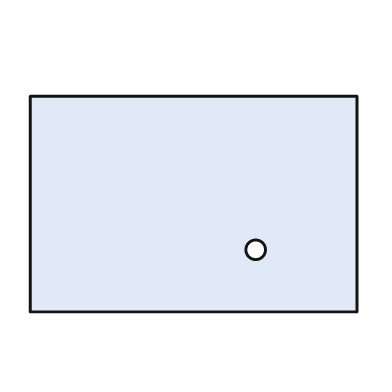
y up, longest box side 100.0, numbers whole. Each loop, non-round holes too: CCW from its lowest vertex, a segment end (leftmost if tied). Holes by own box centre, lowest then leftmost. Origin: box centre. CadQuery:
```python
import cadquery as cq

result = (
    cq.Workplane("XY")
    .moveTo(-50.0, -33.0)
    .lineTo(50.0, -33.0)
    .lineTo(50.0, 33.0)
    .lineTo(-50.0, 33.0)
    .close()
    .moveTo(19.0, -14.0)
    .circle(3.0)
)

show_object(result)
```